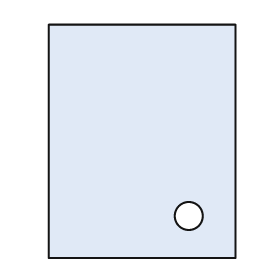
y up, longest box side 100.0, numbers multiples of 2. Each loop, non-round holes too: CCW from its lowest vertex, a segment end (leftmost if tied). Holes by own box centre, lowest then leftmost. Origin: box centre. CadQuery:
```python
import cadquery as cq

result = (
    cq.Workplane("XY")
    .moveTo(-40.0, -50.0)
    .lineTo(40.0, -50.0)
    .lineTo(40.0, 50.0)
    .lineTo(-40.0, 50.0)
    .close()
    .moveTo(20.0, -32.0)
    .circle(6.0)
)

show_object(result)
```